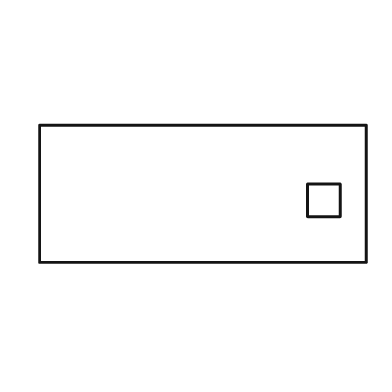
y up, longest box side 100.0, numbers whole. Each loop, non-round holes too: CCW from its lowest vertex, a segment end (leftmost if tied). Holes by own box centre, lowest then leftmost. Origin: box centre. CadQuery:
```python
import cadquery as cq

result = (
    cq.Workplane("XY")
    .moveTo(-50.0, -21.0)
    .lineTo(50.0, -21.0)
    .lineTo(50.0, 21.0)
    .lineTo(-50.0, 21.0)
    .close()
    .moveTo(32.0, -7.0)
    .lineTo(42.0, -7.0)
    .lineTo(42.0, 3.0)
    .lineTo(32.0, 3.0)
    .close()
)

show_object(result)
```